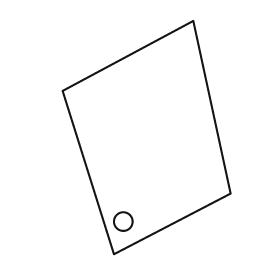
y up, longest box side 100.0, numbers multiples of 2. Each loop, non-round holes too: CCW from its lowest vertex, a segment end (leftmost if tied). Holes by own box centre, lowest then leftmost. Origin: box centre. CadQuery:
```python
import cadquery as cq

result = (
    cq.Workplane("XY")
    .moveTo(-14.0, -50.0)
    .lineTo(36.0, -24.0)
    .lineTo(20.0, 50.0)
    .lineTo(-36.0, 20.0)
    .close()
    .moveTo(-10.0, -36.0)
    .circle(4.0)
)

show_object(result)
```